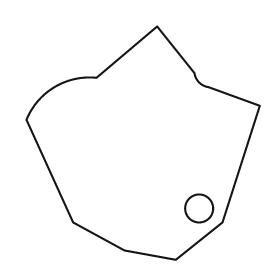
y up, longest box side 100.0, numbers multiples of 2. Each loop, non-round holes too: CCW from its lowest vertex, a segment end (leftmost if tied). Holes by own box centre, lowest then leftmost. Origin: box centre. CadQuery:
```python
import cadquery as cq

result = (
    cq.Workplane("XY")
    .moveTo(14.0, -50.0)
    .lineTo(34.0, -34.0)
    .lineTo(50.0, 16.0)
    .lineTo(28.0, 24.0)
    .threePointArc((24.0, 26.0), (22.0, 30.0))
    .lineTo(6.0, 50.0)
    .lineTo(-20.0, 28.0)
    .threePointArc((-38.0, 24.0), (-50.0, 10.0))
    .lineTo(-30.0, -34.0)
    .lineTo(-8.0, -46.0)
    .close()
    .moveTo(24.0, -28.0)
    .circle(6.0)
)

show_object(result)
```